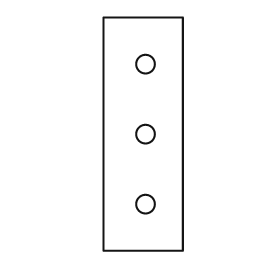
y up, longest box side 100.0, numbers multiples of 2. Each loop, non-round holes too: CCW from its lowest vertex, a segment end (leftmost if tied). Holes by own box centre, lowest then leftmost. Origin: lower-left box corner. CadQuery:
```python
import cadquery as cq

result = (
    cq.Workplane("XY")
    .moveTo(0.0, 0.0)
    .lineTo(34.0, 0.0)
    .lineTo(34.0, 100.0)
    .lineTo(0.0, 100.0)
    .close()
    .moveTo(18.0, 20.0)
    .circle(4.0)
    .moveTo(18.0, 50.0)
    .circle(4.0)
    .moveTo(18.0, 80.0)
    .circle(4.0)
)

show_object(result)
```